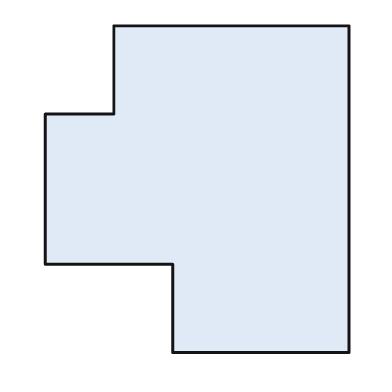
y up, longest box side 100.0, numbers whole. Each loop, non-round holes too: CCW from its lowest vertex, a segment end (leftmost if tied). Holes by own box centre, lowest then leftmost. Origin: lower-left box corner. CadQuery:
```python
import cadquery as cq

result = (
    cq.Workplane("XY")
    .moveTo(39.0, 0.0)
    .lineTo(93.0, 0.0)
    .lineTo(93.0, 100.0)
    .lineTo(21.0, 100.0)
    .lineTo(21.0, 73.0)
    .lineTo(0.0, 73.0)
    .lineTo(0.0, 27.0)
    .lineTo(39.0, 27.0)
    .close()
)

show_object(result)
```